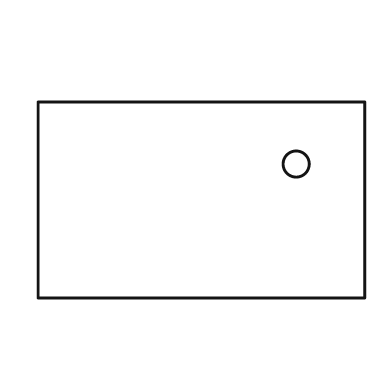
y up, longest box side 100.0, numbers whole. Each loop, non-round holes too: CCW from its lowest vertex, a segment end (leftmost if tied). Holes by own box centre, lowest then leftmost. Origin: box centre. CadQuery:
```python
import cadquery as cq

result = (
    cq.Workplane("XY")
    .moveTo(-50.0, -30.0)
    .lineTo(50.0, -30.0)
    .lineTo(50.0, 30.0)
    .lineTo(-50.0, 30.0)
    .close()
    .moveTo(29.0, 11.0)
    .circle(4.0)
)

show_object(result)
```